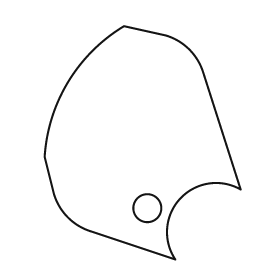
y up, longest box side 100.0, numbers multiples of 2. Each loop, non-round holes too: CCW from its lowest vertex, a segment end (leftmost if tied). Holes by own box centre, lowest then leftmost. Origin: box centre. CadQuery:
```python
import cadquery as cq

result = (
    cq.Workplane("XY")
    .moveTo(14.0, -50.0)
    .threePointArc((16.0, -24.0), (42.0, -20.0))
    .lineTo(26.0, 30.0)
    .threePointArc((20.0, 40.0), (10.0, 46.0))
    .lineTo(-8.0, 50.0)
    .threePointArc((-32.0, 26.0), (-42.0, -6.0))
    .lineTo(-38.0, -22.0)
    .threePointArc((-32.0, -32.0), (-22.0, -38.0))
    .close()
    .moveTo(2.0, -28.0)
    .circle(6.0)
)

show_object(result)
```